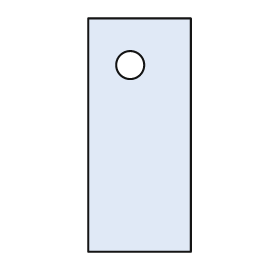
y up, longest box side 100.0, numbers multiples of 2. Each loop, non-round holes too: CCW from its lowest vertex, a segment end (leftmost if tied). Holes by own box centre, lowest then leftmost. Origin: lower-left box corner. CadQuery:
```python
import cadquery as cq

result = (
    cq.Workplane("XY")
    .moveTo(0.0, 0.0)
    .lineTo(44.0, 0.0)
    .lineTo(44.0, 100.0)
    .lineTo(0.0, 100.0)
    .close()
    .moveTo(18.0, 80.0)
    .circle(6.0)
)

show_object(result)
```